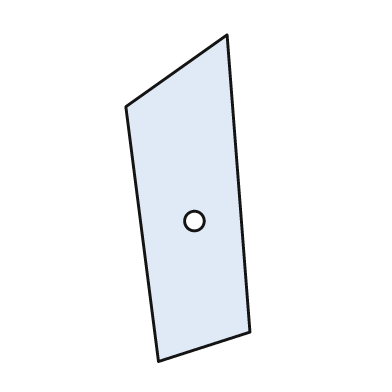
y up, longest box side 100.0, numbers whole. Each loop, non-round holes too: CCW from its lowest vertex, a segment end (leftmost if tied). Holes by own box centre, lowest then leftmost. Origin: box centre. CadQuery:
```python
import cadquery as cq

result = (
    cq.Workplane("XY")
    .moveTo(-9.0, -50.0)
    .lineTo(19.0, -41.0)
    .lineTo(12.0, 50.0)
    .lineTo(-19.0, 28.0)
    .close()
    .moveTo(2.0, -7.0)
    .circle(3.0)
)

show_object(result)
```